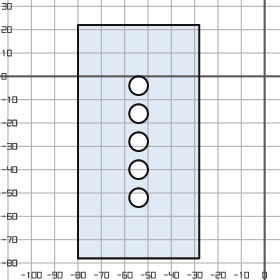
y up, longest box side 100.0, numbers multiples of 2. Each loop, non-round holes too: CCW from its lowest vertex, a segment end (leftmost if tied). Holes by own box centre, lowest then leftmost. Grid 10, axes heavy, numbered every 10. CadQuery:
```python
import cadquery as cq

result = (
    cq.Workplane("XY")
    .moveTo(-80.0, -78.0)
    .lineTo(-28.0, -78.0)
    .lineTo(-28.0, 22.0)
    .lineTo(-80.0, 22.0)
    .close()
    .moveTo(-54.0, -52.0)
    .circle(4.0)
    .moveTo(-54.0, -40.0)
    .circle(4.0)
    .moveTo(-54.0, -28.0)
    .circle(4.0)
    .moveTo(-54.0, -16.0)
    .circle(4.0)
    .moveTo(-54.0, -4.0)
    .circle(4.0)
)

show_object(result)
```